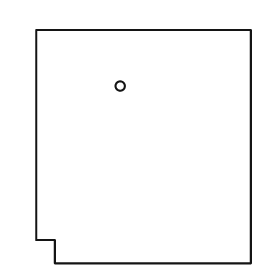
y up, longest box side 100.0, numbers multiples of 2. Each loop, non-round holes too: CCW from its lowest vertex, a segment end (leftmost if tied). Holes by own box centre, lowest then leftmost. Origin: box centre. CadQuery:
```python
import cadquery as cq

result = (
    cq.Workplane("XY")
    .moveTo(-38.0, -50.0)
    .lineTo(46.0, -50.0)
    .lineTo(46.0, 50.0)
    .lineTo(-46.0, 50.0)
    .lineTo(-46.0, -40.0)
    .lineTo(-38.0, -40.0)
    .close()
    .moveTo(-10.0, 26.0)
    .circle(2.0)
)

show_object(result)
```